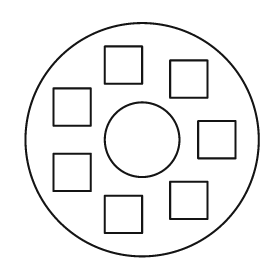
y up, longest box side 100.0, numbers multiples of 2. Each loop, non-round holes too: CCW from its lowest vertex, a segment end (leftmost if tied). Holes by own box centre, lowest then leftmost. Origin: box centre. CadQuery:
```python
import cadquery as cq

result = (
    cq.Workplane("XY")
    .moveTo(0.0, 0.0)
    .circle(50.0)
    .moveTo(-16.0, -40.0)
    .lineTo(0.0, -40.0)
    .lineTo(0.0, -24.0)
    .lineTo(-16.0, -24.0)
    .close()
    .moveTo(12.0, -34.0)
    .lineTo(28.0, -34.0)
    .lineTo(28.0, -18.0)
    .lineTo(12.0, -18.0)
    .close()
    .moveTo(-38.0, -22.0)
    .lineTo(-22.0, -22.0)
    .lineTo(-22.0, -6.0)
    .lineTo(-38.0, -6.0)
    .close()
    .moveTo(0.0, 0.0)
    .circle(16.0)
    .moveTo(24.0, -8.0)
    .lineTo(40.0, -8.0)
    .lineTo(40.0, 8.0)
    .lineTo(24.0, 8.0)
    .close()
    .moveTo(-38.0, 6.0)
    .lineTo(-22.0, 6.0)
    .lineTo(-22.0, 22.0)
    .lineTo(-38.0, 22.0)
    .close()
    .moveTo(12.0, 18.0)
    .lineTo(28.0, 18.0)
    .lineTo(28.0, 34.0)
    .lineTo(12.0, 34.0)
    .close()
    .moveTo(-16.0, 24.0)
    .lineTo(0.0, 24.0)
    .lineTo(0.0, 40.0)
    .lineTo(-16.0, 40.0)
    .close()
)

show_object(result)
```